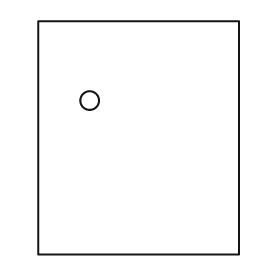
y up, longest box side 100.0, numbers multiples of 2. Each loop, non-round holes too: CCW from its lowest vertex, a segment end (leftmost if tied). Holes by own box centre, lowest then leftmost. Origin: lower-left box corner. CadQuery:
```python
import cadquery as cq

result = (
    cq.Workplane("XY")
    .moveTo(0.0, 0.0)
    .lineTo(86.0, 0.0)
    .lineTo(86.0, 100.0)
    .lineTo(0.0, 100.0)
    .close()
    .moveTo(22.0, 66.0)
    .circle(4.0)
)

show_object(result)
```